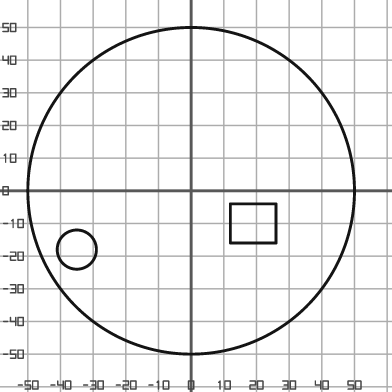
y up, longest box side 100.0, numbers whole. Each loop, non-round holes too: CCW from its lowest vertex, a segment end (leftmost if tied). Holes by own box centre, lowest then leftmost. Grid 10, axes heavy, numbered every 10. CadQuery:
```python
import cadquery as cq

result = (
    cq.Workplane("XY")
    .moveTo(0.0, 0.0)
    .circle(50.0)
    .moveTo(-35.0, -18.0)
    .circle(6.0)
    .moveTo(12.0, -16.0)
    .lineTo(26.0, -16.0)
    .lineTo(26.0, -4.0)
    .lineTo(12.0, -4.0)
    .close()
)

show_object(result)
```